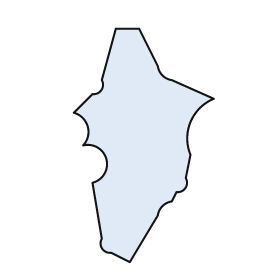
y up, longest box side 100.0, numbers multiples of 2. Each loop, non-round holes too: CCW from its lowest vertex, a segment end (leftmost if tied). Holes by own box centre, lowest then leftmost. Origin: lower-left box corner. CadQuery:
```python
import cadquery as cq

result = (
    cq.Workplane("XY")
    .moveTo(24.0, 0.0)
    .lineTo(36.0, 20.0)
    .threePointArc((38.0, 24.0), (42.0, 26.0))
    .lineTo(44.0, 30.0)
    .threePointArc((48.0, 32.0), (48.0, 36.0))
    .lineTo(50.0, 46.0)
    .threePointArc((50.0, 60.0), (60.0, 70.0))
    .lineTo(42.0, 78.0)
    .threePointArc((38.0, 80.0), (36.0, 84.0))
    .lineTo(28.0, 100.0)
    .lineTo(18.0, 100.0)
    .lineTo(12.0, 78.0)
    .threePointArc((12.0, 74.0), (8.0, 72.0))
    .lineTo(0.0, 64.0)
    .threePointArc((6.0, 58.0), (4.0, 50.0))
    .threePointArc((14.0, 44.0), (8.0, 34.0))
    .lineTo(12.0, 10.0)
    .threePointArc((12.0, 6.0), (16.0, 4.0))
    .close()
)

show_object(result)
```